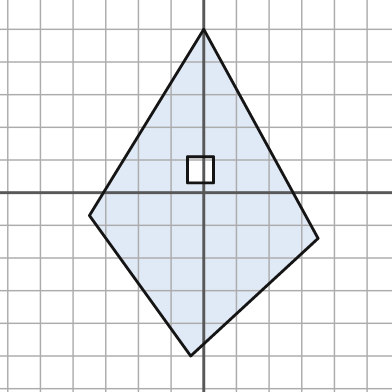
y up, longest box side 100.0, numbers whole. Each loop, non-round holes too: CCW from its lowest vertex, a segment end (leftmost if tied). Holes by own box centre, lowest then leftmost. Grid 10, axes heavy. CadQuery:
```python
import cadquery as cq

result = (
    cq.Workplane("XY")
    .moveTo(-4.0, -50.0)
    .lineTo(35.0, -14.0)
    .lineTo(0.0, 50.0)
    .lineTo(-35.0, -7.0)
    .close()
    .moveTo(-5.0, 3.0)
    .lineTo(3.0, 3.0)
    .lineTo(3.0, 11.0)
    .lineTo(-5.0, 11.0)
    .close()
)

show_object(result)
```